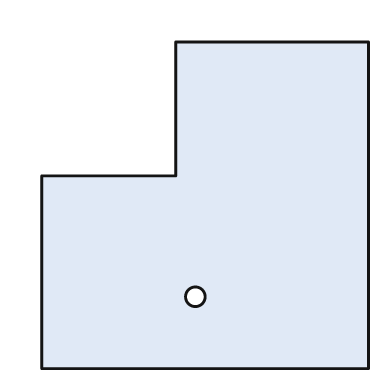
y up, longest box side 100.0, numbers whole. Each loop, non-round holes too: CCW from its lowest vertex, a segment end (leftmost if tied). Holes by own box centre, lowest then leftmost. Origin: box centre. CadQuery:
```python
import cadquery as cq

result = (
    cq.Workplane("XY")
    .moveTo(-50.0, -50.0)
    .lineTo(50.0, -50.0)
    .lineTo(50.0, 50.0)
    .lineTo(-9.0, 50.0)
    .lineTo(-9.0, 9.0)
    .lineTo(-50.0, 9.0)
    .close()
    .moveTo(-3.0, -28.0)
    .circle(3.0)
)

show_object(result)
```